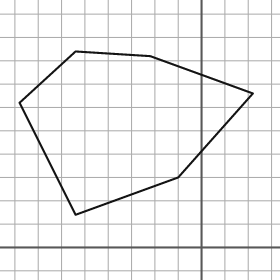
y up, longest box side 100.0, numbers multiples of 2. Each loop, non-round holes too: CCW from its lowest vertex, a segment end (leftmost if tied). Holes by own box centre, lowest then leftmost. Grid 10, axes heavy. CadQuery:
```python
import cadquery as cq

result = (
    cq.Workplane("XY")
    .moveTo(-54.0, 14.0)
    .lineTo(-10.0, 30.0)
    .lineTo(22.0, 66.0)
    .lineTo(-22.0, 82.0)
    .lineTo(-54.0, 84.0)
    .lineTo(-78.0, 62.0)
    .close()
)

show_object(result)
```